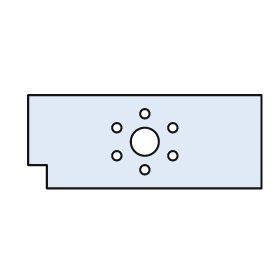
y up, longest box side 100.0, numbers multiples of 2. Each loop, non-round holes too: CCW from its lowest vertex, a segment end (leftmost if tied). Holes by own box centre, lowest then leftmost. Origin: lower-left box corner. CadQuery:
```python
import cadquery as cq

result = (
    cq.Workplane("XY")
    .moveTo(8.0, 0.0)
    .lineTo(100.0, 0.0)
    .lineTo(100.0, 40.0)
    .lineTo(0.0, 40.0)
    .lineTo(0.0, 10.0)
    .lineTo(8.0, 10.0)
    .close()
    .moveTo(50.0, 8.0)
    .circle(2.0)
    .moveTo(38.0, 14.0)
    .circle(2.0)
    .moveTo(62.0, 14.0)
    .circle(2.0)
    .moveTo(50.0, 20.0)
    .circle(6.0)
    .moveTo(38.0, 26.0)
    .circle(2.0)
    .moveTo(62.0, 26.0)
    .circle(2.0)
    .moveTo(50.0, 32.0)
    .circle(2.0)
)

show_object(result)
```